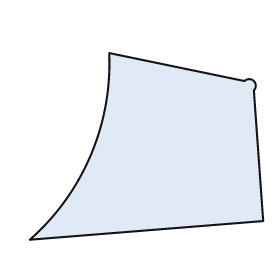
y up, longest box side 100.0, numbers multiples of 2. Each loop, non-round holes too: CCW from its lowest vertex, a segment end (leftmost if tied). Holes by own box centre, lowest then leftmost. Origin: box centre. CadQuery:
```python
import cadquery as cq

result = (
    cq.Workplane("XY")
    .moveTo(-50.0, -40.0)
    .lineTo(50.0, -32.0)
    .lineTo(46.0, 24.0)
    .threePointArc((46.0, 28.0), (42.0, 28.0))
    .lineTo(-16.0, 40.0)
    .threePointArc((-24.0, -4.0), (-50.0, -40.0))
    .close()
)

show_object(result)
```